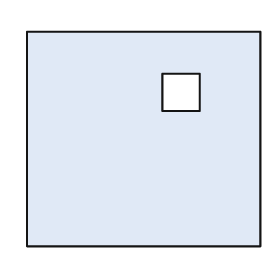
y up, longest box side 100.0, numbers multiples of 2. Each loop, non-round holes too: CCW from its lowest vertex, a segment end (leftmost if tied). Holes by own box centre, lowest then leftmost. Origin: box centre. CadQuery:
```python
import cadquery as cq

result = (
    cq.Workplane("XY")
    .moveTo(-50.0, -46.0)
    .lineTo(50.0, -46.0)
    .lineTo(50.0, 46.0)
    .lineTo(-50.0, 46.0)
    .close()
    .moveTo(8.0, 12.0)
    .lineTo(24.0, 12.0)
    .lineTo(24.0, 28.0)
    .lineTo(8.0, 28.0)
    .close()
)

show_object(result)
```